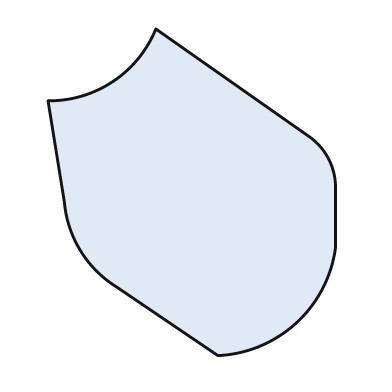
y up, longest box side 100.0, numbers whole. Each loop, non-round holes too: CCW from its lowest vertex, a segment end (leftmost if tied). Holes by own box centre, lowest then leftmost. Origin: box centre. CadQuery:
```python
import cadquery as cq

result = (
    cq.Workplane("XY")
    .moveTo(8.0, -50.0)
    .threePointArc((32.0, -40.0), (44.0, -17.0))
    .lineTo(44.0, 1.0)
    .threePointArc((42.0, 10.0), (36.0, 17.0))
    .lineTo(-11.0, 50.0)
    .threePointArc((-24.0, 34.0), (-44.0, 28.0))
    .lineTo(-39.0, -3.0)
    .threePointArc((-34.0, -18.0), (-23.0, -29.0))
    .close()
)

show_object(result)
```